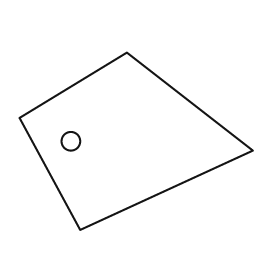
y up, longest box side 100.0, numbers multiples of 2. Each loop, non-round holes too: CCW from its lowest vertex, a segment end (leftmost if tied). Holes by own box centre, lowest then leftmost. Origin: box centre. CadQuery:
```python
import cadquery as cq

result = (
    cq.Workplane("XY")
    .moveTo(-24.0, -38.0)
    .lineTo(50.0, -4.0)
    .lineTo(-4.0, 38.0)
    .lineTo(-50.0, 10.0)
    .close()
    .moveTo(-28.0, 0.0)
    .circle(4.0)
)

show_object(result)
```